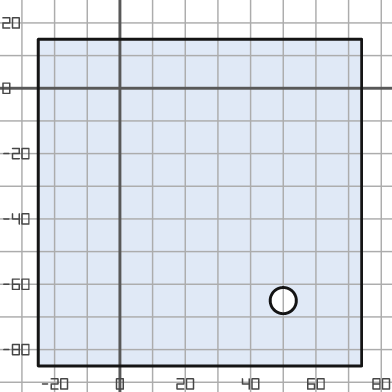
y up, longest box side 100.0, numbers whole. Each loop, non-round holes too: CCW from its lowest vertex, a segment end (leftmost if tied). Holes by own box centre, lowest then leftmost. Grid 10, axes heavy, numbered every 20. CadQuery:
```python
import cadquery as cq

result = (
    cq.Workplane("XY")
    .moveTo(-25.0, -85.0)
    .lineTo(74.0, -85.0)
    .lineTo(74.0, 15.0)
    .lineTo(-25.0, 15.0)
    .close()
    .moveTo(50.0, -65.0)
    .circle(4.0)
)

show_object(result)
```